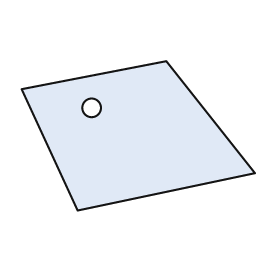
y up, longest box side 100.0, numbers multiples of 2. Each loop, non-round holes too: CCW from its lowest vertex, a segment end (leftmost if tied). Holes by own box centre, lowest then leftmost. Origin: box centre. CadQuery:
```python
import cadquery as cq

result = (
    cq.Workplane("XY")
    .moveTo(-26.0, -32.0)
    .lineTo(50.0, -16.0)
    .lineTo(12.0, 32.0)
    .lineTo(-50.0, 20.0)
    .close()
    .moveTo(-20.0, 12.0)
    .circle(4.0)
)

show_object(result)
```